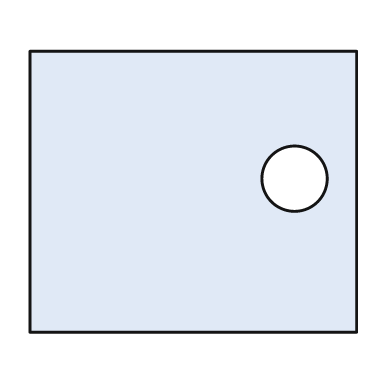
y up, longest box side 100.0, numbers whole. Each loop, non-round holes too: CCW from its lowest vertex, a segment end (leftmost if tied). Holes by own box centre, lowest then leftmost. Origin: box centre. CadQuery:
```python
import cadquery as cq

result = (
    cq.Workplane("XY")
    .moveTo(-50.0, -43.0)
    .lineTo(50.0, -43.0)
    .lineTo(50.0, 43.0)
    .lineTo(-50.0, 43.0)
    .close()
    .moveTo(31.0, 4.0)
    .circle(10.0)
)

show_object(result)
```